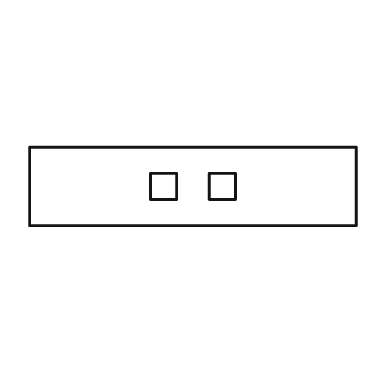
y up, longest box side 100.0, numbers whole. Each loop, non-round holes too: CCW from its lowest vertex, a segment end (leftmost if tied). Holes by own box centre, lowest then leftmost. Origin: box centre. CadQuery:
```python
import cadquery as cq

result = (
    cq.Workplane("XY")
    .moveTo(-50.0, -12.0)
    .lineTo(50.0, -12.0)
    .lineTo(50.0, 12.0)
    .lineTo(-50.0, 12.0)
    .close()
    .moveTo(-13.0, -4.0)
    .lineTo(-5.0, -4.0)
    .lineTo(-5.0, 4.0)
    .lineTo(-13.0, 4.0)
    .close()
    .moveTo(5.0, -4.0)
    .lineTo(13.0, -4.0)
    .lineTo(13.0, 4.0)
    .lineTo(5.0, 4.0)
    .close()
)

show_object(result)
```